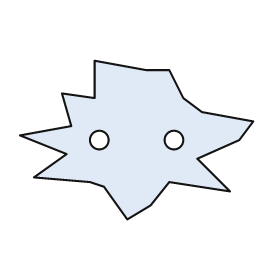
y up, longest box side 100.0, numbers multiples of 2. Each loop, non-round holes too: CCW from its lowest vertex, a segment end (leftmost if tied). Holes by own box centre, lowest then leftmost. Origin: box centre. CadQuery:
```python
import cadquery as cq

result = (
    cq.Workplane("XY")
    .moveTo(-4.0, -34.0)
    .lineTo(6.0, -28.0)
    .lineTo(14.0, -18.0)
    .lineTo(40.0, -22.0)
    .lineTo(26.0, -8.0)
    .lineTo(44.0, 0.0)
    .lineTo(50.0, 8.0)
    .lineTo(28.0, 12.0)
    .lineTo(20.0, 18.0)
    .lineTo(14.0, 30.0)
    .lineTo(4.0, 30.0)
    .lineTo(-18.0, 34.0)
    .lineTo(-18.0, 18.0)
    .lineTo(-32.0, 20.0)
    .lineTo(-28.0, 6.0)
    .lineTo(-50.0, 2.0)
    .lineTo(-30.0, -6.0)
    .lineTo(-44.0, -16.0)
    .lineTo(-20.0, -18.0)
    .lineTo(-14.0, -20.0)
    .close()
    .moveTo(-16.0, 0.0)
    .circle(4.0)
    .moveTo(16.0, 0.0)
    .circle(4.0)
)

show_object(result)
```